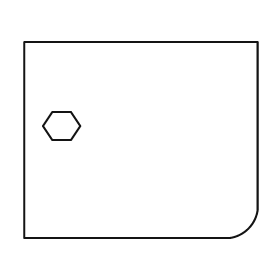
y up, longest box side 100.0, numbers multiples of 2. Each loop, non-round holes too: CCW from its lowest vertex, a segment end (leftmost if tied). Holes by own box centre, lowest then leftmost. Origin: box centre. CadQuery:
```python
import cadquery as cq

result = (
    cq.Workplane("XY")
    .moveTo(-50.0, -42.0)
    .lineTo(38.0, -42.0)
    .threePointArc((46.0, -38.0), (50.0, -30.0))
    .lineTo(50.0, 42.0)
    .lineTo(-50.0, 42.0)
    .close()
    .moveTo(-38.0, 0.0)
    .lineTo(-30.0, 0.0)
    .lineTo(-26.0, 6.0)
    .lineTo(-30.0, 12.0)
    .lineTo(-38.0, 12.0)
    .lineTo(-42.0, 6.0)
    .close()
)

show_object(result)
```